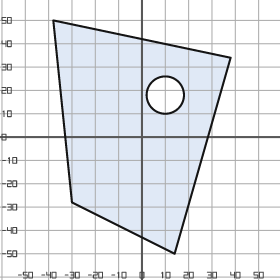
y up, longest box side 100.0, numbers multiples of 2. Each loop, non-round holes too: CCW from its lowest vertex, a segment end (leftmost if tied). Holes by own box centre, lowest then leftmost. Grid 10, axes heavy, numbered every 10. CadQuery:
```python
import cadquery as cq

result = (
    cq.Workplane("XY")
    .moveTo(14.0, -50.0)
    .lineTo(38.0, 34.0)
    .lineTo(-38.0, 50.0)
    .lineTo(-30.0, -28.0)
    .close()
    .moveTo(10.0, 18.0)
    .circle(8.0)
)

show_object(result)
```